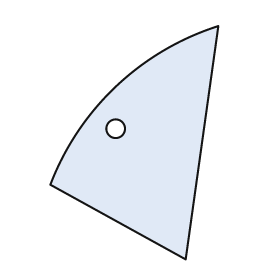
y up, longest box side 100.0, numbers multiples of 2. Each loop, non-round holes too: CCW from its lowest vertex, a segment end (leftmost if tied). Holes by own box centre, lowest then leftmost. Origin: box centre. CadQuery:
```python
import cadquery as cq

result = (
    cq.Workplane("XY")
    .moveTo(22.0, -50.0)
    .lineTo(36.0, 50.0)
    .threePointArc((-8.0, 24.0), (-36.0, -18.0))
    .close()
    .moveTo(-8.0, 6.0)
    .circle(4.0)
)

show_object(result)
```